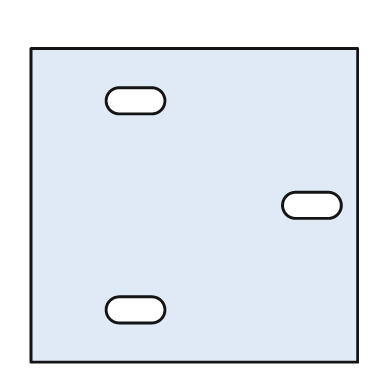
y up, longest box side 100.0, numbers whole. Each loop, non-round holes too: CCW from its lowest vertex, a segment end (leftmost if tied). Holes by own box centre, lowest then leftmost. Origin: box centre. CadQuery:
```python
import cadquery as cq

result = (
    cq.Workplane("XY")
    .moveTo(-50.0, -48.0)
    .lineTo(50.0, -48.0)
    .lineTo(50.0, 48.0)
    .lineTo(-50.0, 48.0)
    .close()
    .moveTo(-23.0, -36.0)
    .lineTo(-13.0, -36.0)
    .threePointArc((-9.0, -32.0), (-13.0, -28.0))
    .lineTo(-23.0, -28.0)
    .threePointArc((-27.0, -32.0), (-23.0, -36.0))
    .close()
    .moveTo(31.0, -4.0)
    .lineTo(41.0, -4.0)
    .threePointArc((45.0, 0.0), (41.0, 4.0))
    .lineTo(31.0, 4.0)
    .threePointArc((27.0, 0.0), (31.0, -4.0))
    .close()
    .moveTo(-23.0, 28.0)
    .lineTo(-13.0, 28.0)
    .threePointArc((-9.0, 32.0), (-13.0, 36.0))
    .lineTo(-23.0, 36.0)
    .threePointArc((-27.0, 32.0), (-23.0, 28.0))
    .close()
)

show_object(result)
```